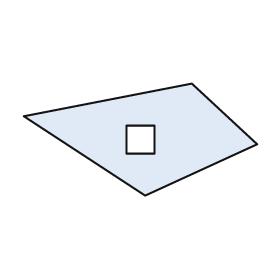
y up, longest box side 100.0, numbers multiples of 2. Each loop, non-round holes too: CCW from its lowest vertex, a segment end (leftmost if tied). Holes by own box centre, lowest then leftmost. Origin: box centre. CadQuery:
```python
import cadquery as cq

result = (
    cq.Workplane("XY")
    .moveTo(2.0, -24.0)
    .lineTo(50.0, -2.0)
    .lineTo(22.0, 24.0)
    .lineTo(-50.0, 10.0)
    .close()
    .moveTo(-6.0, -6.0)
    .lineTo(6.0, -6.0)
    .lineTo(6.0, 6.0)
    .lineTo(-6.0, 6.0)
    .close()
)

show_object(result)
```